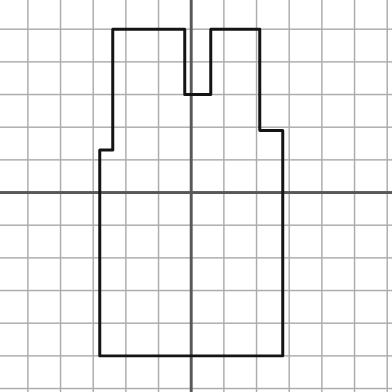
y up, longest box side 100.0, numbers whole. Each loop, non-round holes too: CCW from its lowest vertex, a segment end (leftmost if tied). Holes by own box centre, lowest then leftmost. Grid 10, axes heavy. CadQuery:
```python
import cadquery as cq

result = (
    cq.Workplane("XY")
    .moveTo(-28.0, -50.0)
    .lineTo(28.0, -50.0)
    .lineTo(28.0, 19.0)
    .lineTo(21.0, 19.0)
    .lineTo(21.0, 50.0)
    .lineTo(6.0, 50.0)
    .lineTo(6.0, 30.0)
    .lineTo(-2.0, 30.0)
    .lineTo(-2.0, 50.0)
    .lineTo(-24.0, 50.0)
    .lineTo(-24.0, 13.0)
    .lineTo(-28.0, 13.0)
    .close()
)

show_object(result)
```